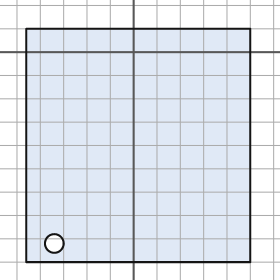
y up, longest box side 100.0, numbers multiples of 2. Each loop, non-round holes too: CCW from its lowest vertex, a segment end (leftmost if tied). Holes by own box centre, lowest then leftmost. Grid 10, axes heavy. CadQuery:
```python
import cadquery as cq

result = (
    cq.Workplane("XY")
    .moveTo(-46.0, -90.0)
    .lineTo(50.0, -90.0)
    .lineTo(50.0, 10.0)
    .lineTo(-46.0, 10.0)
    .close()
    .moveTo(-34.0, -82.0)
    .circle(4.0)
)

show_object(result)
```